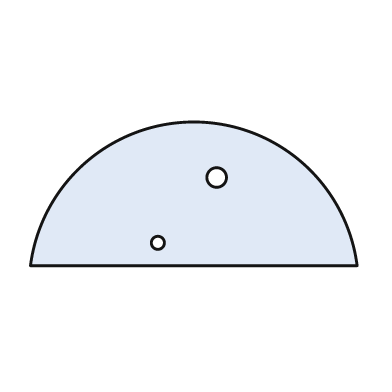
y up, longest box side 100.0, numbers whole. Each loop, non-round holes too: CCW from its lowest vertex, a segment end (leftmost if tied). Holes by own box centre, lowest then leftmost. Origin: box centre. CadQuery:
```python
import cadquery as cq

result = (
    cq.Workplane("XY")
    .moveTo(-50.0, -22.0)
    .lineTo(50.0, -22.0)
    .threePointArc((0.0, 22.0), (-50.0, -22.0))
    .close()
    .moveTo(-11.0, -15.0)
    .circle(2.0)
    .moveTo(7.0, 5.0)
    .circle(3.0)
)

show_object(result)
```